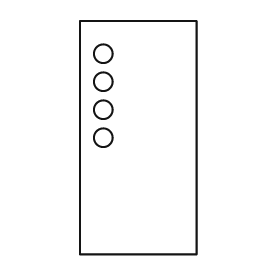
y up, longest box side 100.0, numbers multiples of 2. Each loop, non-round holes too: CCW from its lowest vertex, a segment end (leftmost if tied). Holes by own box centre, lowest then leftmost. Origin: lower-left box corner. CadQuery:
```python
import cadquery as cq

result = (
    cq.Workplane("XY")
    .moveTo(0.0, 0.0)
    .lineTo(50.0, 0.0)
    .lineTo(50.0, 100.0)
    .lineTo(0.0, 100.0)
    .close()
    .moveTo(10.0, 50.0)
    .circle(4.0)
    .moveTo(10.0, 62.0)
    .circle(4.0)
    .moveTo(10.0, 74.0)
    .circle(4.0)
    .moveTo(10.0, 86.0)
    .circle(4.0)
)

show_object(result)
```